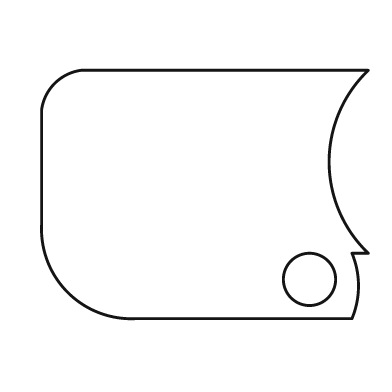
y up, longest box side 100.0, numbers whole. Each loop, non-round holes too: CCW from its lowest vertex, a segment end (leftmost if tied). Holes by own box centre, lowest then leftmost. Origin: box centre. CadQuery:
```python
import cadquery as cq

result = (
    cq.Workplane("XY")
    .moveTo(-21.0, -38.0)
    .lineTo(45.0, -38.0)
    .threePointArc((47.0, -28.0), (45.0, -18.0))
    .lineTo(50.0, -18.0)
    .threePointArc((38.0, 10.0), (50.0, 38.0))
    .lineTo(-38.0, 38.0)
    .threePointArc((-46.0, 34.0), (-50.0, 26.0))
    .lineTo(-50.0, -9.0)
    .threePointArc((-42.0, -30.0), (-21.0, -38.0))
    .close()
    .moveTo(32.0, -26.0)
    .circle(8.0)
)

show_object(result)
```